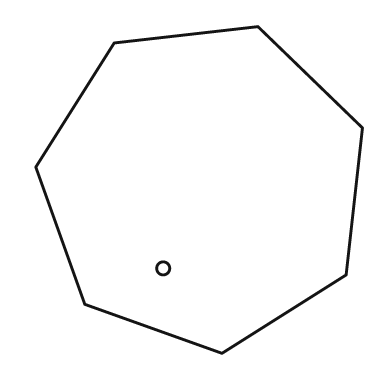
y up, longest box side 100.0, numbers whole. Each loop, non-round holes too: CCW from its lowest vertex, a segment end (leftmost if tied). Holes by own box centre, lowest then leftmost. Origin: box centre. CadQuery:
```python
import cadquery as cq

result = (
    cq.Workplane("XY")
    .moveTo(7.0, -50.0)
    .lineTo(45.0, -26.0)
    .lineTo(50.0, 19.0)
    .lineTo(18.0, 50.0)
    .lineTo(-26.0, 45.0)
    .lineTo(-50.0, 7.0)
    .lineTo(-35.0, -35.0)
    .close()
    .moveTo(-11.0, -24.0)
    .circle(2.0)
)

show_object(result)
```